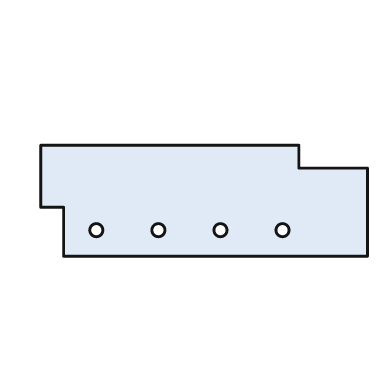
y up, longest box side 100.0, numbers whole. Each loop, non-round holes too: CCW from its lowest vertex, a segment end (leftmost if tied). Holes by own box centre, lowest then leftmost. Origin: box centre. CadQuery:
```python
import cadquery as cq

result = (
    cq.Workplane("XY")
    .moveTo(-43.0, -17.0)
    .lineTo(50.0, -17.0)
    .lineTo(50.0, 10.0)
    .lineTo(29.0, 10.0)
    .lineTo(29.0, 17.0)
    .lineTo(-50.0, 17.0)
    .lineTo(-50.0, -2.0)
    .lineTo(-43.0, -2.0)
    .close()
    .moveTo(-33.0, -9.0)
    .circle(2.0)
    .moveTo(-14.0, -9.0)
    .circle(2.0)
    .moveTo(5.0, -9.0)
    .circle(2.0)
    .moveTo(24.0, -9.0)
    .circle(2.0)
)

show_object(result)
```